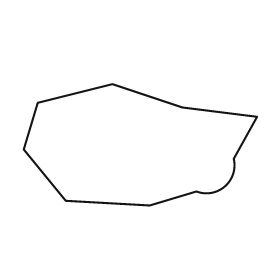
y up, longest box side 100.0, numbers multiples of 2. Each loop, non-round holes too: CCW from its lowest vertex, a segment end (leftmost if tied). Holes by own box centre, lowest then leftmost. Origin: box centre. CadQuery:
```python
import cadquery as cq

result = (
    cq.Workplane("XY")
    .moveTo(4.0, -26.0)
    .lineTo(24.0, -20.0)
    .threePointArc((36.0, -18.0), (40.0, -6.0))
    .lineTo(50.0, 12.0)
    .lineTo(18.0, 16.0)
    .lineTo(-12.0, 26.0)
    .lineTo(-44.0, 18.0)
    .lineTo(-50.0, -2.0)
    .lineTo(-32.0, -24.0)
    .close()
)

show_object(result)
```